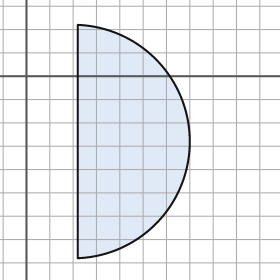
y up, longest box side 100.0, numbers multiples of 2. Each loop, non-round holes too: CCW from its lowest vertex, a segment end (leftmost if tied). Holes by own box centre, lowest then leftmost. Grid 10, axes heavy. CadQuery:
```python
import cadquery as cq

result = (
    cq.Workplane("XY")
    .moveTo(22.0, -78.0)
    .threePointArc((70.0, -28.0), (22.0, 22.0))
    .close()
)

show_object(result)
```